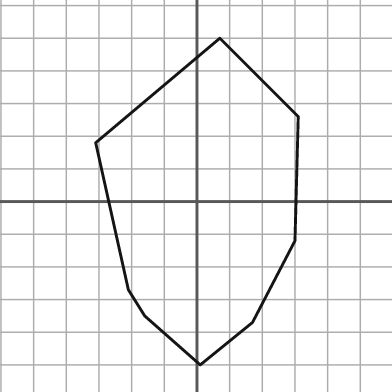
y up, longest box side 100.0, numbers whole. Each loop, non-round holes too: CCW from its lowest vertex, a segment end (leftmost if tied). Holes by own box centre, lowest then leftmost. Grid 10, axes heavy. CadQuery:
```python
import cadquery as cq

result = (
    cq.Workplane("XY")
    .moveTo(1.0, -50.0)
    .lineTo(17.0, -37.0)
    .lineTo(30.0, -12.0)
    .lineTo(31.0, 26.0)
    .lineTo(7.0, 50.0)
    .lineTo(-31.0, 18.0)
    .lineTo(-21.0, -27.0)
    .lineTo(-16.0, -35.0)
    .close()
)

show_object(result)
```